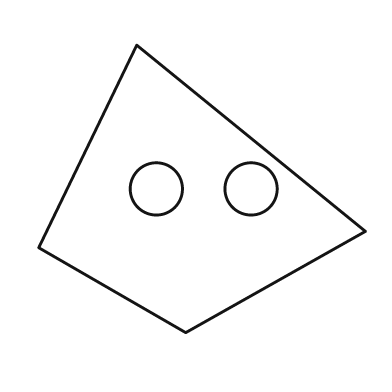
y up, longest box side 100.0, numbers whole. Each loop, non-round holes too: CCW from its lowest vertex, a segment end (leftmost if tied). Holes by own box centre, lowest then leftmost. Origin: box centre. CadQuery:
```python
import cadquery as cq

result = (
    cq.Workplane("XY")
    .moveTo(-5.0, -44.0)
    .lineTo(50.0, -13.0)
    .lineTo(-20.0, 44.0)
    .lineTo(-50.0, -18.0)
    .close()
    .moveTo(-14.0, 0.0)
    .circle(8.0)
    .moveTo(15.0, 0.0)
    .circle(8.0)
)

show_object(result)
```